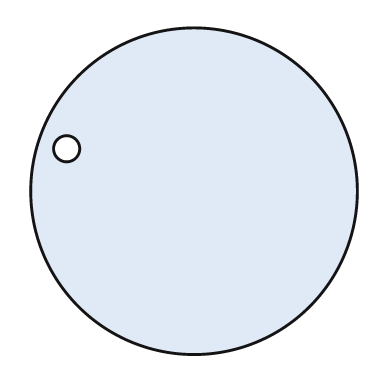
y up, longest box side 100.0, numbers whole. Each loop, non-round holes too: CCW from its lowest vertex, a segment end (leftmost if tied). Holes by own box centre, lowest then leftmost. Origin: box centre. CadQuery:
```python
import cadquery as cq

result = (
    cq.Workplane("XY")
    .moveTo(0.0, 0.0)
    .circle(50.0)
    .moveTo(-39.0, 13.0)
    .circle(4.0)
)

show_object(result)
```